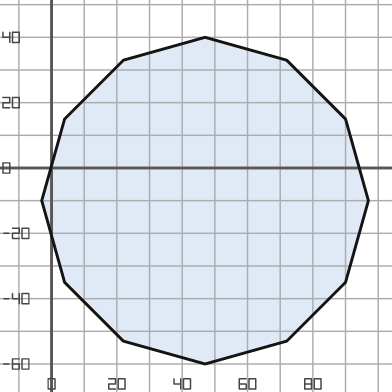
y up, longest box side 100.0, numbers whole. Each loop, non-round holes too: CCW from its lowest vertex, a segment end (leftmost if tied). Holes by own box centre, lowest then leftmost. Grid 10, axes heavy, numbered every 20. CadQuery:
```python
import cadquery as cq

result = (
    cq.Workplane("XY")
    .moveTo(47.0, -60.0)
    .lineTo(72.0, -53.0)
    .lineTo(90.0, -35.0)
    .lineTo(97.0, -10.0)
    .lineTo(90.0, 15.0)
    .lineTo(72.0, 33.0)
    .lineTo(47.0, 40.0)
    .lineTo(22.0, 33.0)
    .lineTo(4.0, 15.0)
    .lineTo(-3.0, -10.0)
    .lineTo(4.0, -35.0)
    .lineTo(22.0, -53.0)
    .close()
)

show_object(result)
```